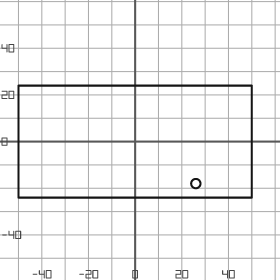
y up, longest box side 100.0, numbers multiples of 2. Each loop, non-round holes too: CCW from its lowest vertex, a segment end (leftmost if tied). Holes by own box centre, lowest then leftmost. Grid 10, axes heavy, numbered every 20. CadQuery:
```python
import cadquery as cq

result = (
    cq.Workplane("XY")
    .moveTo(-50.0, -24.0)
    .lineTo(50.0, -24.0)
    .lineTo(50.0, 24.0)
    .lineTo(-50.0, 24.0)
    .close()
    .moveTo(26.0, -18.0)
    .circle(2.0)
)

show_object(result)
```